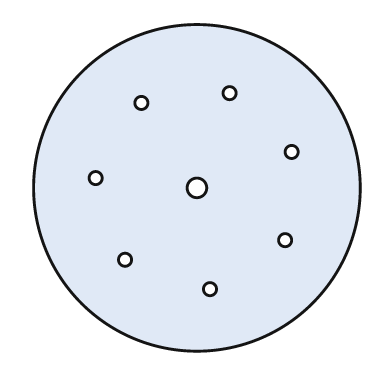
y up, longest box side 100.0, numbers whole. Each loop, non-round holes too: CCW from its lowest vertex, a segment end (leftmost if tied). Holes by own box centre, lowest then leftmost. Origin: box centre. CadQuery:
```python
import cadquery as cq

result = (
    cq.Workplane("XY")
    .moveTo(0.0, 0.0)
    .circle(50.0)
    .moveTo(4.0, -31.0)
    .circle(2.0)
    .moveTo(-22.0, -22.0)
    .circle(2.0)
    .moveTo(27.0, -16.0)
    .circle(2.0)
    .moveTo(0.0, 0.0)
    .circle(3.0)
    .moveTo(-31.0, 3.0)
    .circle(2.0)
    .moveTo(29.0, 11.0)
    .circle(2.0)
    .moveTo(-17.0, 26.0)
    .circle(2.0)
    .moveTo(10.0, 29.0)
    .circle(2.0)
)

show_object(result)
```